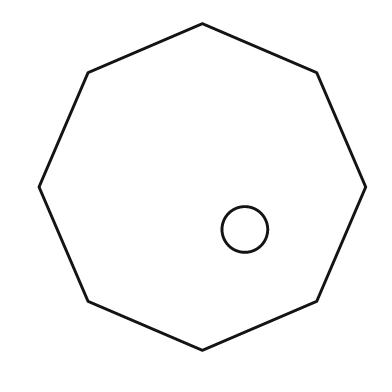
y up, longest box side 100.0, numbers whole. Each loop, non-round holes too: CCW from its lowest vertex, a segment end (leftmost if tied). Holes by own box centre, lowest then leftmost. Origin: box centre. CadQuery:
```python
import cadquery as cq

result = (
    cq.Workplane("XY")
    .moveTo(0.0, -50.0)
    .lineTo(35.0, -35.0)
    .lineTo(50.0, 0.0)
    .lineTo(35.0, 35.0)
    .lineTo(0.0, 50.0)
    .lineTo(-35.0, 35.0)
    .lineTo(-50.0, 0.0)
    .lineTo(-35.0, -35.0)
    .close()
    .moveTo(13.0, -13.0)
    .circle(7.0)
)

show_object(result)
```